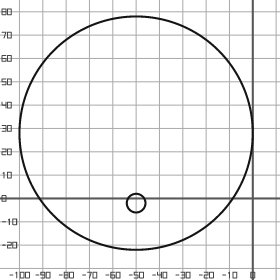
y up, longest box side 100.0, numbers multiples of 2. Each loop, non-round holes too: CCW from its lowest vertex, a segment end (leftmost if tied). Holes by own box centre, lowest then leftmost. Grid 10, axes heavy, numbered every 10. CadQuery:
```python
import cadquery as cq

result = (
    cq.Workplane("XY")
    .moveTo(-50.0, 28.0)
    .circle(50.0)
    .moveTo(-50.0, -2.0)
    .circle(4.0)
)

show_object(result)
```